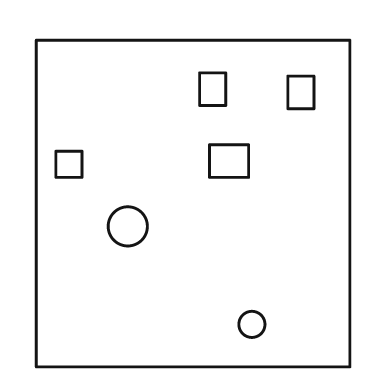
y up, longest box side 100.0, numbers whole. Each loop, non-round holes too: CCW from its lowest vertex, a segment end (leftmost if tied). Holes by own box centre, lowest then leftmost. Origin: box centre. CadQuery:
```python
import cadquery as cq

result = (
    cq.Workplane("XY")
    .moveTo(-48.0, -50.0)
    .lineTo(48.0, -50.0)
    .lineTo(48.0, 50.0)
    .lineTo(-48.0, 50.0)
    .close()
    .moveTo(18.0, -37.0)
    .circle(4.0)
    .moveTo(-20.0, -7.0)
    .circle(6.0)
    .moveTo(-42.0, 8.0)
    .lineTo(-34.0, 8.0)
    .lineTo(-34.0, 16.0)
    .lineTo(-42.0, 16.0)
    .close()
    .moveTo(5.0, 8.0)
    .lineTo(17.0, 8.0)
    .lineTo(17.0, 18.0)
    .lineTo(5.0, 18.0)
    .close()
    .moveTo(29.0, 29.0)
    .lineTo(37.0, 29.0)
    .lineTo(37.0, 39.0)
    .lineTo(29.0, 39.0)
    .close()
    .moveTo(2.0, 30.0)
    .lineTo(10.0, 30.0)
    .lineTo(10.0, 40.0)
    .lineTo(2.0, 40.0)
    .close()
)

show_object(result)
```